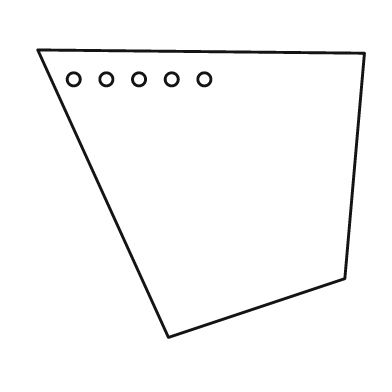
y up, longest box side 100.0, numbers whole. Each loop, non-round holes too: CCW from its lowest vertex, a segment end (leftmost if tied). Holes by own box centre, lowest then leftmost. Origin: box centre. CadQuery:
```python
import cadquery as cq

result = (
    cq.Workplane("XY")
    .moveTo(-10.0, -44.0)
    .lineTo(44.0, -26.0)
    .lineTo(50.0, 43.0)
    .lineTo(-50.0, 44.0)
    .close()
    .moveTo(-39.0, 35.0)
    .circle(2.0)
    .moveTo(-29.0, 35.0)
    .circle(2.0)
    .moveTo(-19.0, 35.0)
    .circle(2.0)
    .moveTo(-9.0, 35.0)
    .circle(2.0)
    .moveTo(1.0, 35.0)
    .circle(2.0)
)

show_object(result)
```